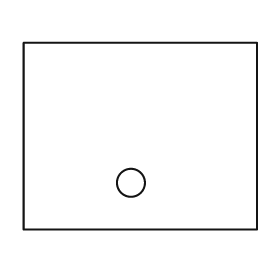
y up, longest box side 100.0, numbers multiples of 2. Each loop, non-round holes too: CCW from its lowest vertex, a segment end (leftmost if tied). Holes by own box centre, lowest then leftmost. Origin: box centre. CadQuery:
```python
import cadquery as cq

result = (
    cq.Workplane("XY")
    .moveTo(-50.0, -40.0)
    .lineTo(50.0, -40.0)
    .lineTo(50.0, 40.0)
    .lineTo(-50.0, 40.0)
    .close()
    .moveTo(-4.0, -20.0)
    .circle(6.0)
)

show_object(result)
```